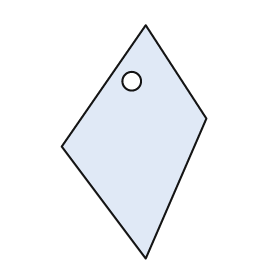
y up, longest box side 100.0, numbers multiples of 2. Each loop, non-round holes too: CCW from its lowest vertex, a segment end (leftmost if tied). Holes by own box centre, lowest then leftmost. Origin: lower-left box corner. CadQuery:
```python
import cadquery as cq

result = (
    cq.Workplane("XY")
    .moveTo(36.0, 0.0)
    .lineTo(62.0, 60.0)
    .lineTo(36.0, 100.0)
    .lineTo(0.0, 48.0)
    .close()
    .moveTo(30.0, 76.0)
    .circle(4.0)
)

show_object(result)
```